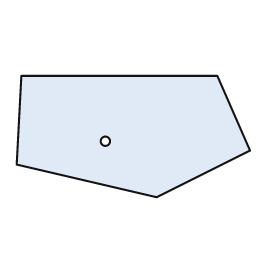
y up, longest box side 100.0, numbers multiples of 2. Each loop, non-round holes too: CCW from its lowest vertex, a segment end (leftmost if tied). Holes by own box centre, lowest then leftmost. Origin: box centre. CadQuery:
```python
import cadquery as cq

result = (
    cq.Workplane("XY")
    .moveTo(10.0, -26.0)
    .lineTo(50.0, -6.0)
    .lineTo(36.0, 26.0)
    .lineTo(-48.0, 26.0)
    .lineTo(-50.0, -12.0)
    .close()
    .moveTo(-12.0, -2.0)
    .circle(2.0)
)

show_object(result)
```